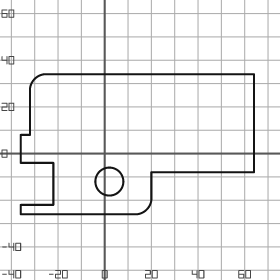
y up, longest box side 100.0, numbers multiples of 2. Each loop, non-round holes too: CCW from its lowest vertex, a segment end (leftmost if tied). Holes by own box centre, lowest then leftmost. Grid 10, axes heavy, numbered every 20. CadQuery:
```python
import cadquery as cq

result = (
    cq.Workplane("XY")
    .moveTo(-36.0, -26.0)
    .lineTo(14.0, -26.0)
    .threePointArc((18.0, -24.0), (20.0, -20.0))
    .lineTo(20.0, -8.0)
    .lineTo(64.0, -8.0)
    .lineTo(64.0, 34.0)
    .lineTo(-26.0, 34.0)
    .threePointArc((-30.0, 32.0), (-32.0, 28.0))
    .lineTo(-32.0, 8.0)
    .lineTo(-36.0, 8.0)
    .lineTo(-36.0, -4.0)
    .lineTo(-22.0, -4.0)
    .lineTo(-22.0, -22.0)
    .lineTo(-36.0, -22.0)
    .close()
    .moveTo(2.0, -12.0)
    .circle(6.0)
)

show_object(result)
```